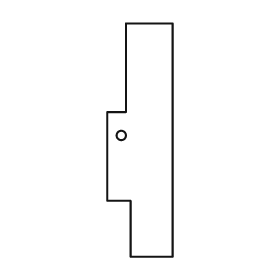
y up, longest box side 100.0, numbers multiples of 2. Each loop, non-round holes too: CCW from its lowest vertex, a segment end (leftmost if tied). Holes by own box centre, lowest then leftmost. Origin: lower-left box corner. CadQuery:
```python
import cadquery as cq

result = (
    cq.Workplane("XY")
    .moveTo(10.0, 0.0)
    .lineTo(28.0, 0.0)
    .lineTo(28.0, 100.0)
    .lineTo(8.0, 100.0)
    .lineTo(8.0, 62.0)
    .lineTo(0.0, 62.0)
    .lineTo(0.0, 24.0)
    .lineTo(10.0, 24.0)
    .close()
    .moveTo(6.0, 52.0)
    .circle(2.0)
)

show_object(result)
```